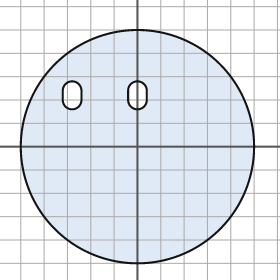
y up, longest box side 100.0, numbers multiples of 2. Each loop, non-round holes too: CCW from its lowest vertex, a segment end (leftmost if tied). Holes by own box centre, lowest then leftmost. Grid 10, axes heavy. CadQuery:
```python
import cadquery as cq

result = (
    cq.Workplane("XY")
    .moveTo(0.0, 0.0)
    .circle(50.0)
    .moveTo(-32.0, 20.0)
    .threePointArc((-28.0, 16.0), (-24.0, 20.0))
    .lineTo(-24.0, 24.0)
    .threePointArc((-28.0, 28.0), (-32.0, 24.0))
    .close()
    .moveTo(-4.0, 20.0)
    .threePointArc((0.0, 16.0), (4.0, 20.0))
    .lineTo(4.0, 24.0)
    .threePointArc((0.0, 28.0), (-4.0, 24.0))
    .close()
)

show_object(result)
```